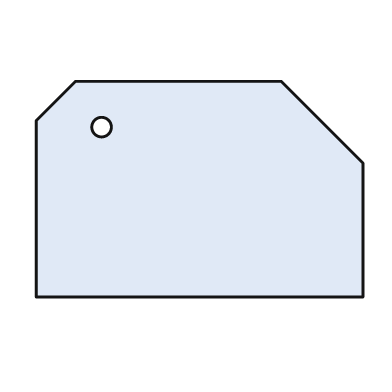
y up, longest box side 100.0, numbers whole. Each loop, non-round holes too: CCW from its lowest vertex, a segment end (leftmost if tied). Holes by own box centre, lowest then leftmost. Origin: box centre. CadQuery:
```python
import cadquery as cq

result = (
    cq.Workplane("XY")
    .moveTo(-50.0, -33.0)
    .lineTo(50.0, -33.0)
    .lineTo(50.0, 8.0)
    .lineTo(25.0, 33.0)
    .lineTo(-38.0, 33.0)
    .lineTo(-50.0, 21.0)
    .close()
    .moveTo(-30.0, 19.0)
    .circle(3.0)
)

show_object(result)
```